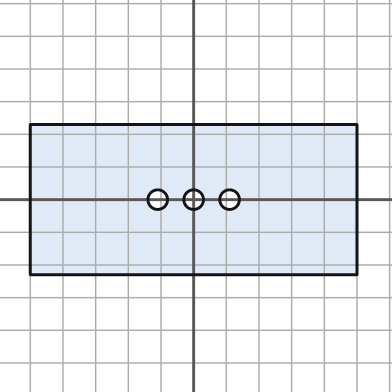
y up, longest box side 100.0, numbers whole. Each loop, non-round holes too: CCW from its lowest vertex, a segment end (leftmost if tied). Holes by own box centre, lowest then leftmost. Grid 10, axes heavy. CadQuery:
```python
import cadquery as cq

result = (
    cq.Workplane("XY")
    .moveTo(-50.0, -23.0)
    .lineTo(50.0, -23.0)
    .lineTo(50.0, 23.0)
    .lineTo(-50.0, 23.0)
    .close()
    .moveTo(-11.0, 0.0)
    .circle(3.0)
    .moveTo(0.0, 0.0)
    .circle(3.0)
    .moveTo(11.0, 0.0)
    .circle(3.0)
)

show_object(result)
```